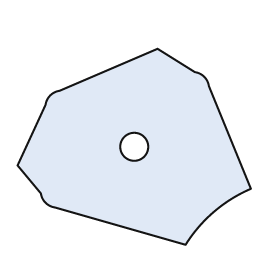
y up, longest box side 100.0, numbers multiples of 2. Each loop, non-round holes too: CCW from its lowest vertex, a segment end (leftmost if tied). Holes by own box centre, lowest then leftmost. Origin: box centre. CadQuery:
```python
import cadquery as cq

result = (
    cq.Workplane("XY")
    .moveTo(22.0, -42.0)
    .threePointArc((34.0, -28.0), (50.0, -18.0))
    .lineTo(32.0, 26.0)
    .threePointArc((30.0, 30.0), (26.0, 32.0))
    .lineTo(10.0, 42.0)
    .lineTo(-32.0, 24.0)
    .threePointArc((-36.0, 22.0), (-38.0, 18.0))
    .lineTo(-50.0, -8.0)
    .lineTo(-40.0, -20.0)
    .threePointArc((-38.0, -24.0), (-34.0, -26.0))
    .close()
    .moveTo(0.0, 0.0)
    .circle(6.0)
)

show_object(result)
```